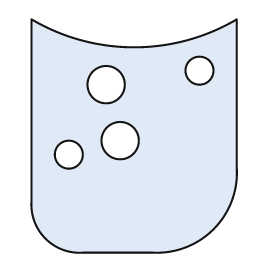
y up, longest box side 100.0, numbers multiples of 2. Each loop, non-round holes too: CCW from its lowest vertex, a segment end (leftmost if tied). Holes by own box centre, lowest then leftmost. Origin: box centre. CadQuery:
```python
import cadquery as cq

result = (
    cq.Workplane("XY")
    .moveTo(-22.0, -50.0)
    .lineTo(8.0, -50.0)
    .threePointArc((34.0, -40.0), (44.0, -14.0))
    .lineTo(44.0, 50.0)
    .threePointArc((0.0, 38.0), (-44.0, 50.0))
    .lineTo(-44.0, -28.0)
    .threePointArc((-38.0, -44.0), (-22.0, -50.0))
    .close()
    .moveTo(-28.0, -8.0)
    .circle(6.0)
    .moveTo(-6.0, -2.0)
    .circle(8.0)
    .moveTo(-12.0, 22.0)
    .circle(8.0)
    .moveTo(28.0, 28.0)
    .circle(6.0)
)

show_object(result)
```